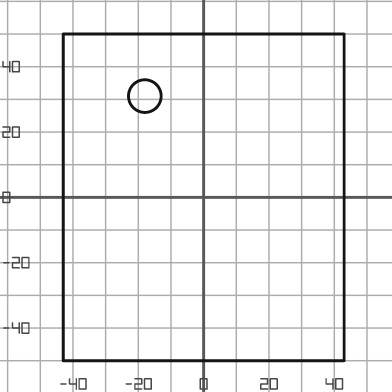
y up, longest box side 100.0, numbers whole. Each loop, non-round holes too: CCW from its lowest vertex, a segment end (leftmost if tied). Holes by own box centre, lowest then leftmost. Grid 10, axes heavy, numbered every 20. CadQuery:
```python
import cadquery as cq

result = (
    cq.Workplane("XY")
    .moveTo(-43.0, -50.0)
    .lineTo(43.0, -50.0)
    .lineTo(43.0, 50.0)
    .lineTo(-43.0, 50.0)
    .close()
    .moveTo(-18.0, 31.0)
    .circle(5.0)
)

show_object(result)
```